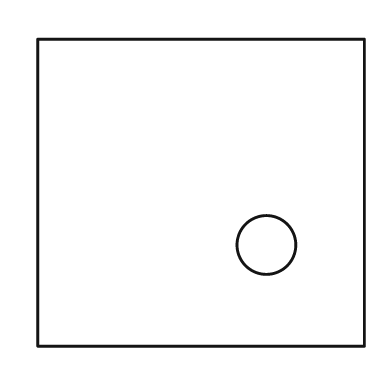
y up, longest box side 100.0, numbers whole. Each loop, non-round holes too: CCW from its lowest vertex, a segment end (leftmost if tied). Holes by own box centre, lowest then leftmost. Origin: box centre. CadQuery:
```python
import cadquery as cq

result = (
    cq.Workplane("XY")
    .moveTo(-50.0, -47.0)
    .lineTo(50.0, -47.0)
    .lineTo(50.0, 47.0)
    .lineTo(-50.0, 47.0)
    .close()
    .moveTo(20.0, -16.0)
    .circle(9.0)
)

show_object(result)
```